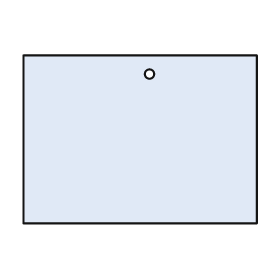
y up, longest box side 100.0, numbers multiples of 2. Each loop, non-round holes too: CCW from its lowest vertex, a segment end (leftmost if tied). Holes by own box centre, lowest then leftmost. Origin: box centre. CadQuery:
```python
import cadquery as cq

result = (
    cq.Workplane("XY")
    .moveTo(-50.0, -36.0)
    .lineTo(50.0, -36.0)
    .lineTo(50.0, 36.0)
    .lineTo(-50.0, 36.0)
    .close()
    .moveTo(4.0, 28.0)
    .circle(2.0)
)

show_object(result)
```